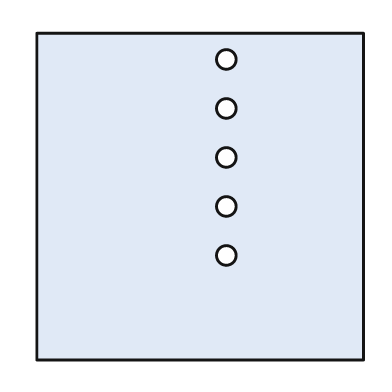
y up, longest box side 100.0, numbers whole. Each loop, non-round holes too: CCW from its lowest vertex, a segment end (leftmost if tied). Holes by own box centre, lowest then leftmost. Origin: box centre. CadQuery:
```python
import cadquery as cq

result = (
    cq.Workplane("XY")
    .moveTo(-50.0, -50.0)
    .lineTo(50.0, -50.0)
    .lineTo(50.0, 50.0)
    .lineTo(-50.0, 50.0)
    .close()
    .moveTo(8.0, -18.0)
    .circle(3.0)
    .moveTo(8.0, -3.0)
    .circle(3.0)
    .moveTo(8.0, 12.0)
    .circle(3.0)
    .moveTo(8.0, 27.0)
    .circle(3.0)
    .moveTo(8.0, 42.0)
    .circle(3.0)
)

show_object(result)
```